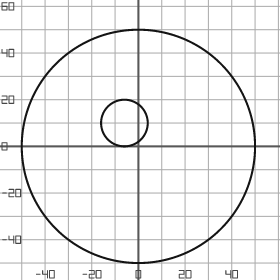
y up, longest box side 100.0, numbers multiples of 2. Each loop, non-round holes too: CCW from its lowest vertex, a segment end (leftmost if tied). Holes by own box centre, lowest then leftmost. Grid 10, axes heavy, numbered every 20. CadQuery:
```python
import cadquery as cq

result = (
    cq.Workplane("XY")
    .moveTo(0.0, 0.0)
    .circle(50.0)
    .moveTo(-6.0, 10.0)
    .circle(10.0)
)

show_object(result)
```